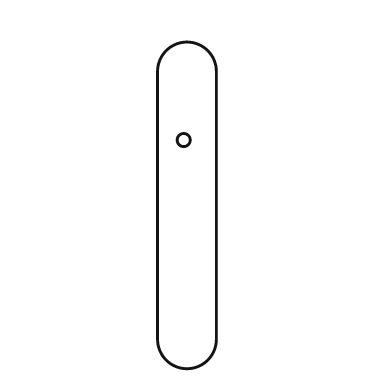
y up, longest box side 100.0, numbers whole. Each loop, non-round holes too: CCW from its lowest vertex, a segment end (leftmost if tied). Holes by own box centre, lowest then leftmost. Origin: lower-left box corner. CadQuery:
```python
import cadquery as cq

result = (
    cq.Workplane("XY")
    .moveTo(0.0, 9.0)
    .threePointArc((9.0, 0.0), (18.0, 9.0))
    .lineTo(18.0, 91.0)
    .threePointArc((9.0, 100.0), (0.0, 91.0))
    .close()
    .moveTo(8.0, 70.0)
    .circle(2.0)
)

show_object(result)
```